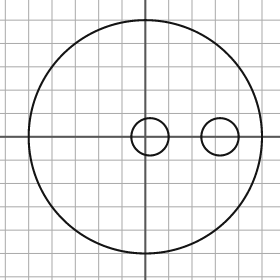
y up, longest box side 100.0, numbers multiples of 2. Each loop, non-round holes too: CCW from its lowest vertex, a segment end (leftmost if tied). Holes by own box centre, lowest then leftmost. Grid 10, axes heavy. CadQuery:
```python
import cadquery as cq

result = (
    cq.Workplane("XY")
    .moveTo(0.0, 0.0)
    .circle(50.0)
    .moveTo(2.0, 0.0)
    .circle(8.0)
    .moveTo(32.0, 0.0)
    .circle(8.0)
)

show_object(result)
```